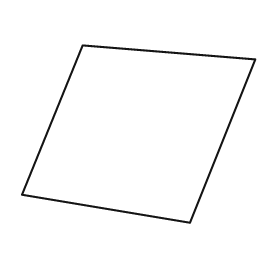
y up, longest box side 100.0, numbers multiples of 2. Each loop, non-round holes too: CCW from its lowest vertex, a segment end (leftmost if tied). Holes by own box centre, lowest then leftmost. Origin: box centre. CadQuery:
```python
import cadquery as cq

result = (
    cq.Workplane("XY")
    .moveTo(22.0, -38.0)
    .lineTo(50.0, 32.0)
    .lineTo(-24.0, 38.0)
    .lineTo(-50.0, -26.0)
    .close()
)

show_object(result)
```